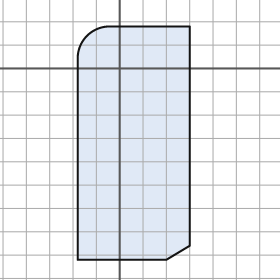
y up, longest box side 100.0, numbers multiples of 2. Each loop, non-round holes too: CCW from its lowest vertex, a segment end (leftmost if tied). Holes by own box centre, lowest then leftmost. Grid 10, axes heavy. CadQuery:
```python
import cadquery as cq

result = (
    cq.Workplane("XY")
    .moveTo(-18.0, -82.0)
    .lineTo(20.0, -82.0)
    .lineTo(30.0, -76.0)
    .lineTo(30.0, 18.0)
    .lineTo(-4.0, 18.0)
    .threePointArc((-14.0, 14.0), (-18.0, 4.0))
    .close()
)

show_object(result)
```